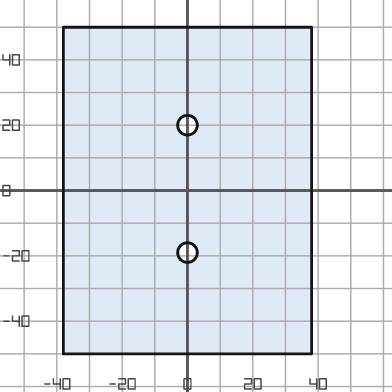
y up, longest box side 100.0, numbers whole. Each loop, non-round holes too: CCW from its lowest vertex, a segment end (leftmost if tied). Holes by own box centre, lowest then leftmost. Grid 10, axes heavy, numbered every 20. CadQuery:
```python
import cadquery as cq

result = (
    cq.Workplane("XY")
    .moveTo(-38.0, -50.0)
    .lineTo(38.0, -50.0)
    .lineTo(38.0, 50.0)
    .lineTo(-38.0, 50.0)
    .close()
    .moveTo(0.0, -19.0)
    .circle(3.0)
    .moveTo(0.0, 20.0)
    .circle(3.0)
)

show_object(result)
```